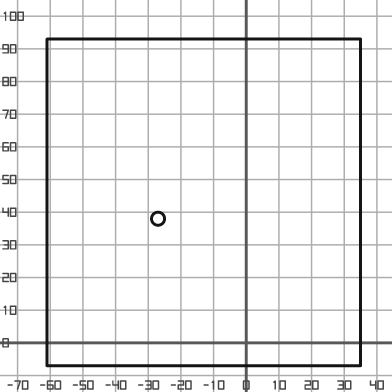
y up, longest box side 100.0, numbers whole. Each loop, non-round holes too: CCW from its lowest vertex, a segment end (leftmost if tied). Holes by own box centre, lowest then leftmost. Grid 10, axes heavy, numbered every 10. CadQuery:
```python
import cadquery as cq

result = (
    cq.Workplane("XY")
    .moveTo(-61.0, -7.0)
    .lineTo(35.0, -7.0)
    .lineTo(35.0, 93.0)
    .lineTo(-61.0, 93.0)
    .close()
    .moveTo(-27.0, 38.0)
    .circle(2.0)
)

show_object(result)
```